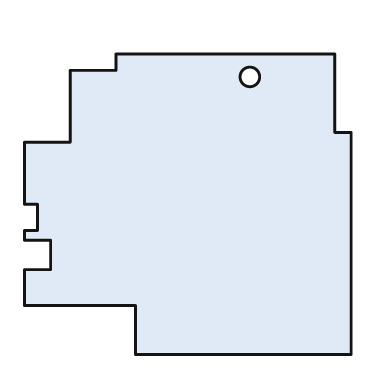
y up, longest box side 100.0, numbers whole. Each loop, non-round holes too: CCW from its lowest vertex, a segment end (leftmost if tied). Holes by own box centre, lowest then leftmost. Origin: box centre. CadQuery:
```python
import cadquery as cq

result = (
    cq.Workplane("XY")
    .moveTo(-16.0, -46.0)
    .lineTo(50.0, -46.0)
    .lineTo(50.0, 22.0)
    .lineTo(45.0, 22.0)
    .lineTo(45.0, 46.0)
    .lineTo(-22.0, 46.0)
    .lineTo(-22.0, 41.0)
    .lineTo(-36.0, 41.0)
    .lineTo(-36.0, 19.0)
    .lineTo(-50.0, 19.0)
    .lineTo(-50.0, 0.0)
    .lineTo(-46.0, 0.0)
    .lineTo(-46.0, -8.0)
    .lineTo(-50.0, -8.0)
    .lineTo(-50.0, -11.0)
    .lineTo(-42.0, -11.0)
    .lineTo(-42.0, -20.0)
    .lineTo(-50.0, -20.0)
    .lineTo(-50.0, -31.0)
    .lineTo(-16.0, -31.0)
    .close()
    .moveTo(19.0, 39.0)
    .circle(3.0)
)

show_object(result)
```